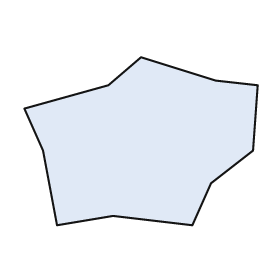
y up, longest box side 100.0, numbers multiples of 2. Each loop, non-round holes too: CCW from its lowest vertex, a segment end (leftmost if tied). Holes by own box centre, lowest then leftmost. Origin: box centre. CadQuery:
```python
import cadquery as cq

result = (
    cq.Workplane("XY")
    .moveTo(-36.0, -36.0)
    .lineTo(-12.0, -32.0)
    .lineTo(22.0, -36.0)
    .lineTo(30.0, -18.0)
    .lineTo(48.0, -4.0)
    .lineTo(50.0, 24.0)
    .lineTo(32.0, 26.0)
    .lineTo(0.0, 36.0)
    .lineTo(-14.0, 24.0)
    .lineTo(-50.0, 14.0)
    .lineTo(-42.0, -4.0)
    .close()
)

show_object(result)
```